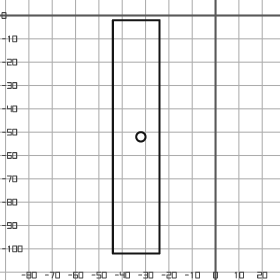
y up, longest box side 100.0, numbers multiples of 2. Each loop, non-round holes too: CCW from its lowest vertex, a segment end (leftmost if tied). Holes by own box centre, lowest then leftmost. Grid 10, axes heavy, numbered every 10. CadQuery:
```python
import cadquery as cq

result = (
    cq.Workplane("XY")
    .moveTo(-44.0, -102.0)
    .lineTo(-24.0, -102.0)
    .lineTo(-24.0, -2.0)
    .lineTo(-44.0, -2.0)
    .close()
    .moveTo(-32.0, -52.0)
    .circle(2.0)
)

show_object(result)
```